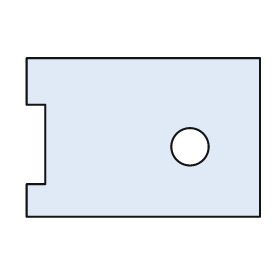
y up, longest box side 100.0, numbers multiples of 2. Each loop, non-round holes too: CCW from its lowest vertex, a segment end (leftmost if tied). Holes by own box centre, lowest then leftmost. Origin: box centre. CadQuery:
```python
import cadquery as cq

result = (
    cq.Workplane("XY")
    .moveTo(-50.0, -34.0)
    .lineTo(50.0, -34.0)
    .lineTo(50.0, 34.0)
    .lineTo(-50.0, 34.0)
    .lineTo(-50.0, 14.0)
    .lineTo(-42.0, 14.0)
    .lineTo(-42.0, -20.0)
    .lineTo(-50.0, -20.0)
    .close()
    .moveTo(20.0, -4.0)
    .circle(8.0)
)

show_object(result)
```